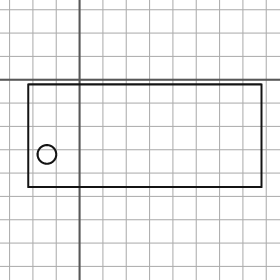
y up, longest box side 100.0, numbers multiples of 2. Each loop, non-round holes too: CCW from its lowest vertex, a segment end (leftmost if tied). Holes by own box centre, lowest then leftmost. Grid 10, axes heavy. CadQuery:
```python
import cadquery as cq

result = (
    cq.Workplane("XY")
    .moveTo(-22.0, -46.0)
    .lineTo(78.0, -46.0)
    .lineTo(78.0, -2.0)
    .lineTo(-22.0, -2.0)
    .close()
    .moveTo(-14.0, -32.0)
    .circle(4.0)
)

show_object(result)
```